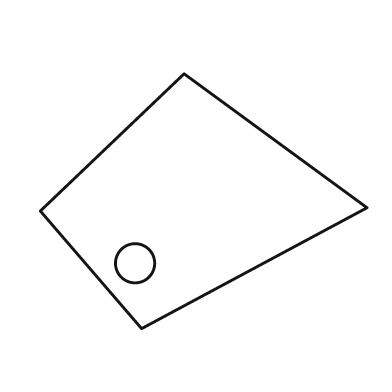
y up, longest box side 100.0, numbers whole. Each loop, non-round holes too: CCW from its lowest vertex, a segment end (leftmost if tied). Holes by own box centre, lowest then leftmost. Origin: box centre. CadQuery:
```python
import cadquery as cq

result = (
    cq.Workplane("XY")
    .moveTo(-19.0, -39.0)
    .lineTo(50.0, -2.0)
    .lineTo(-6.0, 39.0)
    .lineTo(-50.0, -3.0)
    .close()
    .moveTo(-21.0, -19.0)
    .circle(6.0)
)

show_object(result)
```